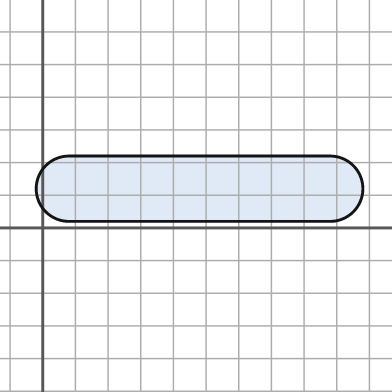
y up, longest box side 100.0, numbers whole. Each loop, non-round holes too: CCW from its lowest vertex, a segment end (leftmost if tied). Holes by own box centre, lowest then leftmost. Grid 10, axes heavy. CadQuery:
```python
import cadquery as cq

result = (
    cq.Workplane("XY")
    .moveTo(8.0, 2.0)
    .lineTo(88.0, 2.0)
    .threePointArc((98.0, 12.0), (88.0, 22.0))
    .lineTo(8.0, 22.0)
    .threePointArc((-2.0, 12.0), (8.0, 2.0))
    .close()
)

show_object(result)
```